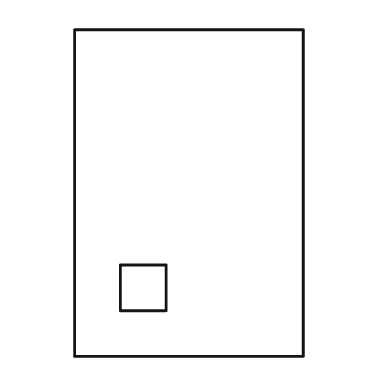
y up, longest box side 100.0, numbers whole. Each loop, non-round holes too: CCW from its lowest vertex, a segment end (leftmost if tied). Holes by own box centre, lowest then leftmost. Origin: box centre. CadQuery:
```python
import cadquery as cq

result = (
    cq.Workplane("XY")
    .moveTo(-35.0, -50.0)
    .lineTo(35.0, -50.0)
    .lineTo(35.0, 50.0)
    .lineTo(-35.0, 50.0)
    .close()
    .moveTo(-21.0, -36.0)
    .lineTo(-7.0, -36.0)
    .lineTo(-7.0, -22.0)
    .lineTo(-21.0, -22.0)
    .close()
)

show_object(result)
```